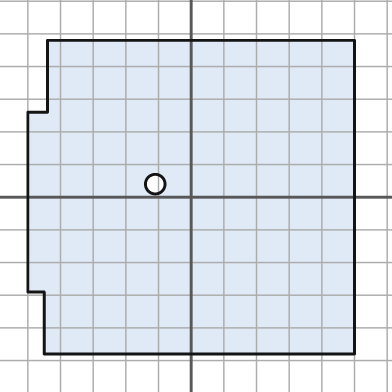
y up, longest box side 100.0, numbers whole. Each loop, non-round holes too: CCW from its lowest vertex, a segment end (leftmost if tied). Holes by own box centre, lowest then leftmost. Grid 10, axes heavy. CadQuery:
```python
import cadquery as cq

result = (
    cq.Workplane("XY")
    .moveTo(-45.0, -48.0)
    .lineTo(50.0, -48.0)
    .lineTo(50.0, 48.0)
    .lineTo(-44.0, 48.0)
    .lineTo(-44.0, 26.0)
    .lineTo(-50.0, 26.0)
    .lineTo(-50.0, -29.0)
    .lineTo(-45.0, -29.0)
    .close()
    .moveTo(-11.0, 4.0)
    .circle(3.0)
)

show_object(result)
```